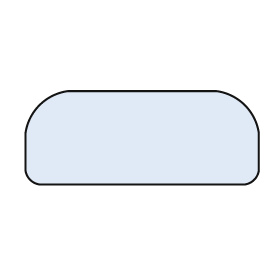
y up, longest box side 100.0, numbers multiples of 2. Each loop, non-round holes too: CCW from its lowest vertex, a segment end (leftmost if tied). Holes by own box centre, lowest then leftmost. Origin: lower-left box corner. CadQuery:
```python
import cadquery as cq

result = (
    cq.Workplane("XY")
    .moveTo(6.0, 0.0)
    .lineTo(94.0, 0.0)
    .threePointArc((98.0, 2.0), (100.0, 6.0))
    .lineTo(100.0, 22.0)
    .threePointArc((94.0, 34.0), (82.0, 40.0))
    .lineTo(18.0, 40.0)
    .threePointArc((6.0, 34.0), (0.0, 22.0))
    .lineTo(0.0, 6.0)
    .threePointArc((2.0, 2.0), (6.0, 0.0))
    .close()
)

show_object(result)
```